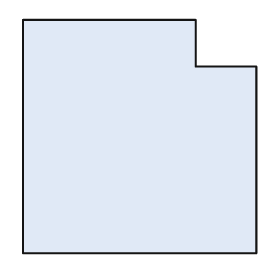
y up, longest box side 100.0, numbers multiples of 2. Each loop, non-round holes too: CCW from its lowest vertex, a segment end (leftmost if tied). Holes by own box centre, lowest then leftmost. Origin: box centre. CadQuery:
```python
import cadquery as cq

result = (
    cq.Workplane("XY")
    .moveTo(-50.0, -50.0)
    .lineTo(50.0, -50.0)
    .lineTo(50.0, 30.0)
    .lineTo(24.0, 30.0)
    .lineTo(24.0, 50.0)
    .lineTo(-50.0, 50.0)
    .close()
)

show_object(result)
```